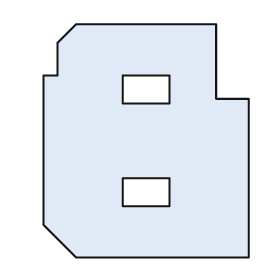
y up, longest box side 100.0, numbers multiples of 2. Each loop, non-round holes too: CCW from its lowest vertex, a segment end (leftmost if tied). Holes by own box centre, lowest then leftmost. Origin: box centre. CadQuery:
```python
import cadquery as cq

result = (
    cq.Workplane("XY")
    .moveTo(-30.0, -50.0)
    .lineTo(44.0, -50.0)
    .lineTo(44.0, 18.0)
    .lineTo(30.0, 18.0)
    .lineTo(30.0, 50.0)
    .lineTo(-30.0, 50.0)
    .lineTo(-38.0, 42.0)
    .lineTo(-38.0, 28.0)
    .lineTo(-44.0, 28.0)
    .lineTo(-44.0, -36.0)
    .close()
    .moveTo(-10.0, -28.0)
    .lineTo(10.0, -28.0)
    .lineTo(10.0, -16.0)
    .lineTo(-10.0, -16.0)
    .close()
    .moveTo(-10.0, 16.0)
    .lineTo(10.0, 16.0)
    .lineTo(10.0, 28.0)
    .lineTo(-10.0, 28.0)
    .close()
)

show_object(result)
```